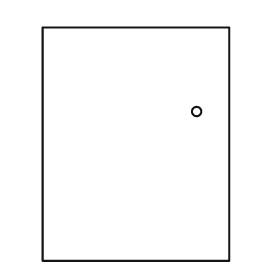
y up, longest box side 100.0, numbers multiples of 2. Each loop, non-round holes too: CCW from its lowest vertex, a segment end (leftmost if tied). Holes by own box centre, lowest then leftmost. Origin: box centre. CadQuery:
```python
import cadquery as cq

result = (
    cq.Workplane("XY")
    .moveTo(-40.0, -50.0)
    .lineTo(40.0, -50.0)
    .lineTo(40.0, 50.0)
    .lineTo(-40.0, 50.0)
    .close()
    .moveTo(26.0, 14.0)
    .circle(2.0)
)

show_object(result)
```